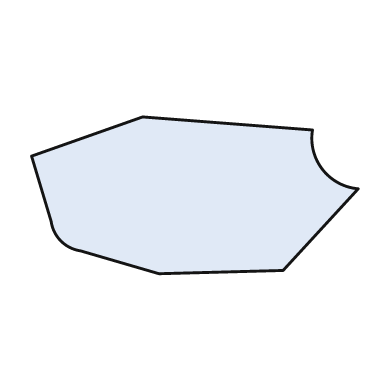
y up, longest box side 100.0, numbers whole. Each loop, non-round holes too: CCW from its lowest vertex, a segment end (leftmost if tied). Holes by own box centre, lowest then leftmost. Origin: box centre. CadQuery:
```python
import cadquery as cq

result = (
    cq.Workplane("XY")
    .moveTo(-11.0, -24.0)
    .lineTo(27.0, -23.0)
    .lineTo(50.0, 2.0)
    .threePointArc((39.0, 8.0), (36.0, 20.0))
    .lineTo(-16.0, 24.0)
    .lineTo(-50.0, 12.0)
    .lineTo(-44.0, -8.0)
    .threePointArc((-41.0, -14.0), (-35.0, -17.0))
    .close()
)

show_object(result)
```